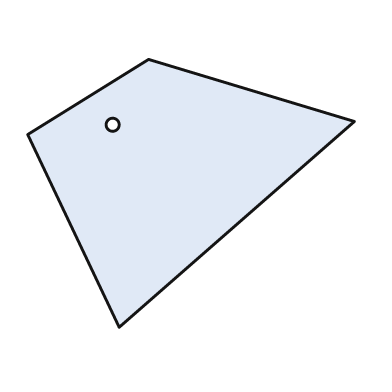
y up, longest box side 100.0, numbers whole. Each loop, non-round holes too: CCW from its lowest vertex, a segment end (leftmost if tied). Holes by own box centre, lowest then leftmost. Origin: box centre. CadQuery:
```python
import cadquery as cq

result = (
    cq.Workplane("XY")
    .moveTo(-22.0, -41.0)
    .lineTo(50.0, 22.0)
    .lineTo(-13.0, 41.0)
    .lineTo(-50.0, 18.0)
    .close()
    .moveTo(-24.0, 21.0)
    .circle(2.0)
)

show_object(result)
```